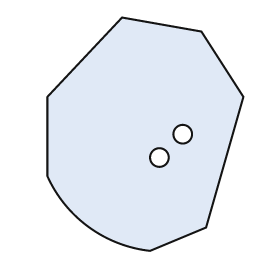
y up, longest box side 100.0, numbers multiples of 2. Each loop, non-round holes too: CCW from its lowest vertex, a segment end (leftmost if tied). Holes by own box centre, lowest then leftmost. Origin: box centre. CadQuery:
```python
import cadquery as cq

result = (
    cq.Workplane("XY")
    .moveTo(2.0, -50.0)
    .lineTo(26.0, -40.0)
    .lineTo(42.0, 16.0)
    .lineTo(24.0, 44.0)
    .lineTo(-10.0, 50.0)
    .lineTo(-42.0, 16.0)
    .lineTo(-42.0, -18.0)
    .threePointArc((-24.0, -40.0), (2.0, -50.0))
    .close()
    .moveTo(6.0, -10.0)
    .circle(4.0)
    .moveTo(16.0, 0.0)
    .circle(4.0)
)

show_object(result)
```